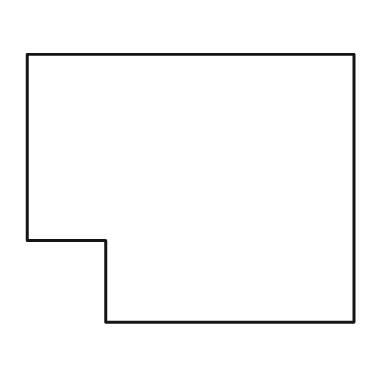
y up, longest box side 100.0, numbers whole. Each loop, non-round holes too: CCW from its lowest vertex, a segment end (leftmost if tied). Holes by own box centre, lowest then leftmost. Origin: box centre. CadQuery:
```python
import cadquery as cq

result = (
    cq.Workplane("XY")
    .moveTo(-26.0, -41.0)
    .lineTo(50.0, -41.0)
    .lineTo(50.0, 41.0)
    .lineTo(-50.0, 41.0)
    .lineTo(-50.0, -16.0)
    .lineTo(-26.0, -16.0)
    .close()
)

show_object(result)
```